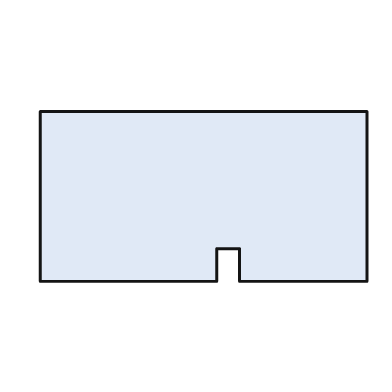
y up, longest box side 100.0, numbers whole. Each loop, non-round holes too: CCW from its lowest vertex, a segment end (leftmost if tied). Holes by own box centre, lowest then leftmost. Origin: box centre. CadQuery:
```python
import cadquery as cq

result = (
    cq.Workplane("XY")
    .moveTo(-50.0, -26.0)
    .lineTo(4.0, -26.0)
    .lineTo(4.0, -16.0)
    .lineTo(11.0, -16.0)
    .lineTo(11.0, -26.0)
    .lineTo(50.0, -26.0)
    .lineTo(50.0, 26.0)
    .lineTo(-50.0, 26.0)
    .close()
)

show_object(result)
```